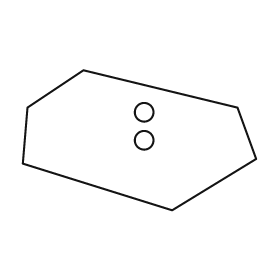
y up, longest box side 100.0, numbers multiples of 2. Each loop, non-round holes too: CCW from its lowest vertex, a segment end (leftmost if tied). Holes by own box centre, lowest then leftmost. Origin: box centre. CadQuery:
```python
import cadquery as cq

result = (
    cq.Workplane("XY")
    .moveTo(14.0, -30.0)
    .lineTo(50.0, -8.0)
    .lineTo(42.0, 14.0)
    .lineTo(-24.0, 30.0)
    .lineTo(-48.0, 14.0)
    .lineTo(-50.0, -10.0)
    .close()
    .moveTo(2.0, 0.0)
    .circle(4.0)
    .moveTo(2.0, 12.0)
    .circle(4.0)
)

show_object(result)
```